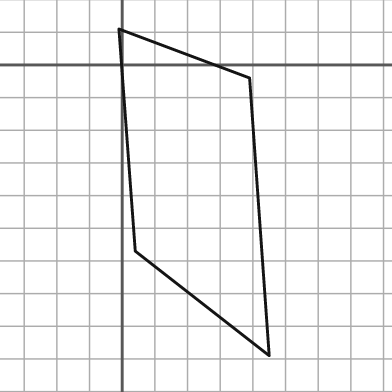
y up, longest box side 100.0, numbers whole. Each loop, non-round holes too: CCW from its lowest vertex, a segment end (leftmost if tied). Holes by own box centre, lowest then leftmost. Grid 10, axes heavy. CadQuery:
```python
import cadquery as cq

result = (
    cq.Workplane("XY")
    .moveTo(45.0, -89.0)
    .lineTo(39.0, -4.0)
    .lineTo(-1.0, 11.0)
    .lineTo(4.0, -57.0)
    .close()
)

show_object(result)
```